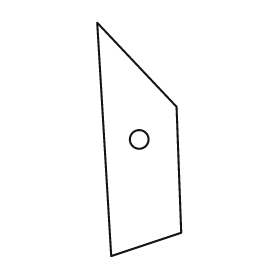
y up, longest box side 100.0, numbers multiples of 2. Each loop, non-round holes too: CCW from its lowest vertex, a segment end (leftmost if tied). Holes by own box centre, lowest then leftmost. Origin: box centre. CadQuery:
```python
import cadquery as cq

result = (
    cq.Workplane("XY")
    .moveTo(-12.0, -50.0)
    .lineTo(18.0, -40.0)
    .lineTo(16.0, 14.0)
    .lineTo(-18.0, 50.0)
    .close()
    .moveTo(0.0, 0.0)
    .circle(4.0)
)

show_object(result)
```